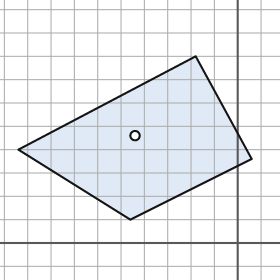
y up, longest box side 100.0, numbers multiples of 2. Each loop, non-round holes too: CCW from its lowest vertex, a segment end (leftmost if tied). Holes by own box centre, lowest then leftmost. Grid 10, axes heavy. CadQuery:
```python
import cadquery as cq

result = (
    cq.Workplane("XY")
    .moveTo(-46.0, 10.0)
    .lineTo(6.0, 36.0)
    .lineTo(-18.0, 80.0)
    .lineTo(-94.0, 40.0)
    .close()
    .moveTo(-44.0, 46.0)
    .circle(2.0)
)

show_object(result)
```